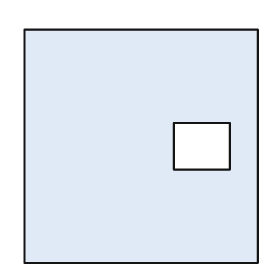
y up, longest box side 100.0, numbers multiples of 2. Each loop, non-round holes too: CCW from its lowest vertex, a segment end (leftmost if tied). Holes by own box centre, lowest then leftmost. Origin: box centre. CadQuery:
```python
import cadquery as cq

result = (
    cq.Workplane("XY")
    .moveTo(-50.0, -50.0)
    .lineTo(50.0, -50.0)
    .lineTo(50.0, 50.0)
    .lineTo(-50.0, 50.0)
    .close()
    .moveTo(14.0, -10.0)
    .lineTo(38.0, -10.0)
    .lineTo(38.0, 10.0)
    .lineTo(14.0, 10.0)
    .close()
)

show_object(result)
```